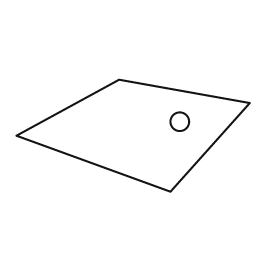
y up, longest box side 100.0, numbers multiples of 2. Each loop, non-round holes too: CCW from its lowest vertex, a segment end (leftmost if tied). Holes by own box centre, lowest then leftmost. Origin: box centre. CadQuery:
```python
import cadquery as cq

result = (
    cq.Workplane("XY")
    .moveTo(16.0, -24.0)
    .lineTo(50.0, 14.0)
    .lineTo(-6.0, 24.0)
    .lineTo(-50.0, 0.0)
    .close()
    .moveTo(20.0, 6.0)
    .circle(4.0)
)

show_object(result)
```